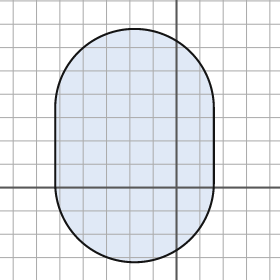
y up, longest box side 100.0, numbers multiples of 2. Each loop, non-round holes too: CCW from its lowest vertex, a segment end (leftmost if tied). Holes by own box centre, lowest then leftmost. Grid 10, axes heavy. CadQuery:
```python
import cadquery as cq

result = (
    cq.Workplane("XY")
    .moveTo(-52.0, 2.0)
    .threePointArc((-18.0, -32.0), (16.0, 2.0))
    .lineTo(16.0, 34.0)
    .threePointArc((-18.0, 68.0), (-52.0, 34.0))
    .close()
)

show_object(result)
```